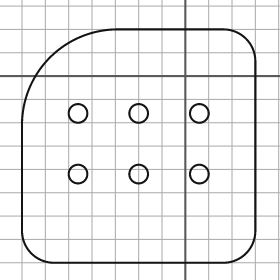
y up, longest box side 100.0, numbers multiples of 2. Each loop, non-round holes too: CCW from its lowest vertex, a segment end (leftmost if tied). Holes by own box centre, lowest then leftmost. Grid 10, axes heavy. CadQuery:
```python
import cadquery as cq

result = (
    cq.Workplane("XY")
    .moveTo(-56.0, -80.0)
    .lineTo(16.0, -80.0)
    .threePointArc((26.0, -76.0), (30.0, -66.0))
    .lineTo(30.0, 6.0)
    .threePointArc((26.0, 16.0), (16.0, 20.0))
    .lineTo(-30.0, 20.0)
    .threePointArc((-58.0, 8.0), (-70.0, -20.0))
    .lineTo(-70.0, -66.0)
    .threePointArc((-66.0, -76.0), (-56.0, -80.0))
    .close()
    .moveTo(-46.0, -42.0)
    .circle(4.0)
    .moveTo(-20.0, -42.0)
    .circle(4.0)
    .moveTo(6.0, -42.0)
    .circle(4.0)
    .moveTo(-46.0, -16.0)
    .circle(4.0)
    .moveTo(-20.0, -16.0)
    .circle(4.0)
    .moveTo(6.0, -16.0)
    .circle(4.0)
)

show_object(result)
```